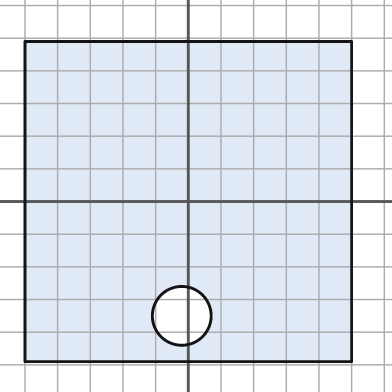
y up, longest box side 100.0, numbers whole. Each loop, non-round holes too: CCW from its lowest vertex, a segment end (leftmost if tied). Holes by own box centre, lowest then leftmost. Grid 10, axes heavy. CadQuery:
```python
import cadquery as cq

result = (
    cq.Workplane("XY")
    .moveTo(-50.0, -49.0)
    .lineTo(50.0, -49.0)
    .lineTo(50.0, 49.0)
    .lineTo(-50.0, 49.0)
    .close()
    .moveTo(-2.0, -35.0)
    .circle(9.0)
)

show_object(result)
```